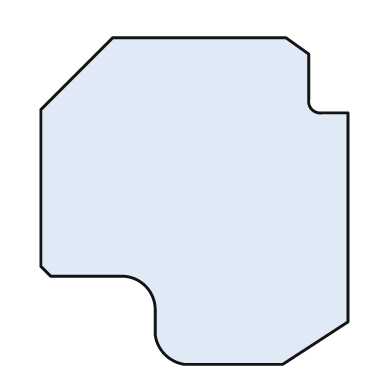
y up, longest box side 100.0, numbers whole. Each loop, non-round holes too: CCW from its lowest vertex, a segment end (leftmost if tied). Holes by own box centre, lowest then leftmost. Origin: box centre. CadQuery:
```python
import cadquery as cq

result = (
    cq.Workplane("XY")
    .moveTo(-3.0, -50.0)
    .lineTo(27.0, -50.0)
    .lineTo(47.0, -37.0)
    .lineTo(47.0, 27.0)
    .lineTo(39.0, 27.0)
    .threePointArc((36.0, 28.0), (35.0, 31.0))
    .lineTo(35.0, 45.0)
    .lineTo(28.0, 50.0)
    .lineTo(-25.0, 50.0)
    .lineTo(-47.0, 28.0)
    .lineTo(-47.0, -20.0)
    .lineTo(-44.0, -23.0)
    .lineTo(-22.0, -23.0)
    .threePointArc((-15.0, -26.0), (-12.0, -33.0))
    .lineTo(-12.0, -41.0)
    .threePointArc((-9.0, -47.0), (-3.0, -50.0))
    .close()
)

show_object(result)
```